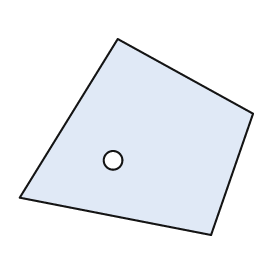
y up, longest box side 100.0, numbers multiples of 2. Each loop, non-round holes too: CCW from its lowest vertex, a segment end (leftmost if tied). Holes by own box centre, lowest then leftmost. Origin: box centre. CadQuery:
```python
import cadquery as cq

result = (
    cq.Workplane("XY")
    .moveTo(32.0, -42.0)
    .lineTo(50.0, 10.0)
    .lineTo(-8.0, 42.0)
    .lineTo(-50.0, -26.0)
    .close()
    .moveTo(-10.0, -10.0)
    .circle(4.0)
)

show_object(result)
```